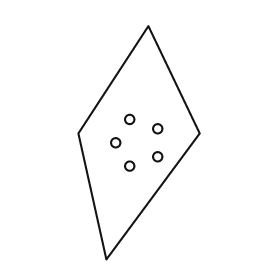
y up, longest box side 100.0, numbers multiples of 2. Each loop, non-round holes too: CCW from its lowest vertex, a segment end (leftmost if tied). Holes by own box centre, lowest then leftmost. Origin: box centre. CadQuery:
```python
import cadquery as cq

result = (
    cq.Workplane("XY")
    .moveTo(-14.0, -50.0)
    .lineTo(26.0, 4.0)
    .lineTo(4.0, 50.0)
    .lineTo(-26.0, 4.0)
    .close()
    .moveTo(-4.0, -10.0)
    .circle(2.0)
    .moveTo(8.0, -6.0)
    .circle(2.0)
    .moveTo(-10.0, 0.0)
    .circle(2.0)
    .moveTo(8.0, 6.0)
    .circle(2.0)
    .moveTo(-4.0, 10.0)
    .circle(2.0)
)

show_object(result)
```